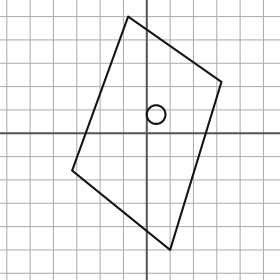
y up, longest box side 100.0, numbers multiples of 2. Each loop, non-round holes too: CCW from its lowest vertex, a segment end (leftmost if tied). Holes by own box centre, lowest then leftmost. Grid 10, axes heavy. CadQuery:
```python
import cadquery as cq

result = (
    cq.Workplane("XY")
    .moveTo(10.0, -50.0)
    .lineTo(32.0, 22.0)
    .lineTo(-8.0, 50.0)
    .lineTo(-32.0, -16.0)
    .close()
    .moveTo(4.0, 8.0)
    .circle(4.0)
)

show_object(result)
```